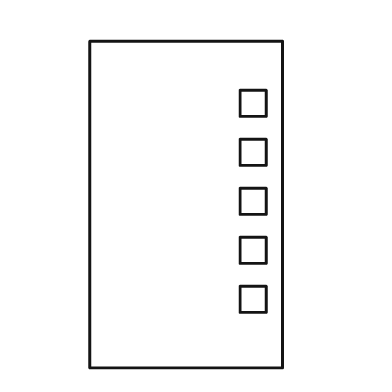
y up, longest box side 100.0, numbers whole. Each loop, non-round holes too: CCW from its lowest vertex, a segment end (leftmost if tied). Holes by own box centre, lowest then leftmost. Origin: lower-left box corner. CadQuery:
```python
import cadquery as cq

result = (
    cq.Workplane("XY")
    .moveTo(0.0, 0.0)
    .lineTo(59.0, 0.0)
    .lineTo(59.0, 100.0)
    .lineTo(0.0, 100.0)
    .close()
    .moveTo(46.0, 17.0)
    .lineTo(54.0, 17.0)
    .lineTo(54.0, 25.0)
    .lineTo(46.0, 25.0)
    .close()
    .moveTo(46.0, 32.0)
    .lineTo(54.0, 32.0)
    .lineTo(54.0, 40.0)
    .lineTo(46.0, 40.0)
    .close()
    .moveTo(46.0, 47.0)
    .lineTo(54.0, 47.0)
    .lineTo(54.0, 55.0)
    .lineTo(46.0, 55.0)
    .close()
    .moveTo(46.0, 62.0)
    .lineTo(54.0, 62.0)
    .lineTo(54.0, 70.0)
    .lineTo(46.0, 70.0)
    .close()
    .moveTo(46.0, 77.0)
    .lineTo(54.0, 77.0)
    .lineTo(54.0, 85.0)
    .lineTo(46.0, 85.0)
    .close()
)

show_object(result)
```